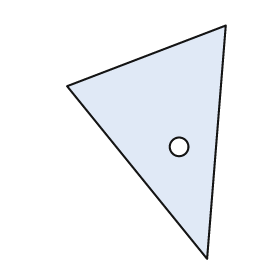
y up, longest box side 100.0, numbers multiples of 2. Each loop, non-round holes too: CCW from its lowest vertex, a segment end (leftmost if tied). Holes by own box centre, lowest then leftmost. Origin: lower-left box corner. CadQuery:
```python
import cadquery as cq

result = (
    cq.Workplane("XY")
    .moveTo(60.0, 0.0)
    .lineTo(68.0, 100.0)
    .lineTo(0.0, 74.0)
    .close()
    .moveTo(48.0, 48.0)
    .circle(4.0)
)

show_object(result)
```